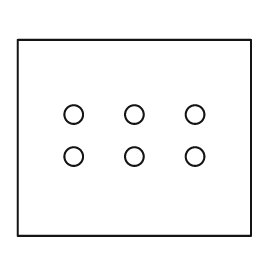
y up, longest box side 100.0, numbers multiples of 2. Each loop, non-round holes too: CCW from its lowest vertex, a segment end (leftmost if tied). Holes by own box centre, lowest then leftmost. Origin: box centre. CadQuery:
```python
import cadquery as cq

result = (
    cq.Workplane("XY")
    .moveTo(-50.0, -42.0)
    .lineTo(50.0, -42.0)
    .lineTo(50.0, 42.0)
    .lineTo(-50.0, 42.0)
    .close()
    .moveTo(-26.0, -8.0)
    .circle(4.0)
    .moveTo(0.0, -8.0)
    .circle(4.0)
    .moveTo(26.0, -8.0)
    .circle(4.0)
    .moveTo(-26.0, 10.0)
    .circle(4.0)
    .moveTo(0.0, 10.0)
    .circle(4.0)
    .moveTo(26.0, 10.0)
    .circle(4.0)
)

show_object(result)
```